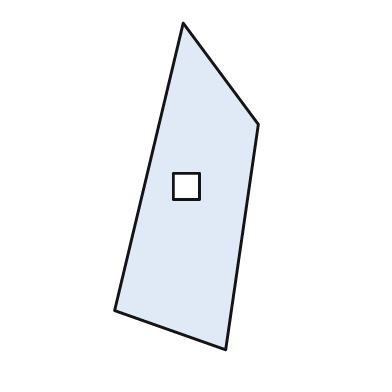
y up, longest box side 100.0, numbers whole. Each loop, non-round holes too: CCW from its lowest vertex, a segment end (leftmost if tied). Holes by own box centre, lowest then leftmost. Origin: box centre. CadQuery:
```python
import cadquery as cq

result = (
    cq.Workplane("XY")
    .moveTo(12.0, -50.0)
    .lineTo(22.0, 19.0)
    .lineTo(-1.0, 50.0)
    .lineTo(-22.0, -38.0)
    .close()
    .moveTo(-4.0, -4.0)
    .lineTo(4.0, -4.0)
    .lineTo(4.0, 4.0)
    .lineTo(-4.0, 4.0)
    .close()
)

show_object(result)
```